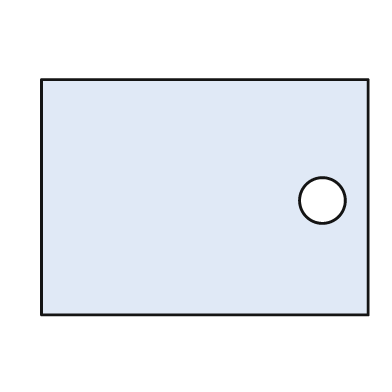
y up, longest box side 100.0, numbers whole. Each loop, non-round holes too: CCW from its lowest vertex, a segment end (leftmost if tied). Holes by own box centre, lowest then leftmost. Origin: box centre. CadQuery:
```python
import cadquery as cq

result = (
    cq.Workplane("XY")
    .moveTo(-50.0, -36.0)
    .lineTo(50.0, -36.0)
    .lineTo(50.0, 36.0)
    .lineTo(-50.0, 36.0)
    .close()
    .moveTo(36.0, -1.0)
    .circle(7.0)
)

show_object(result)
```